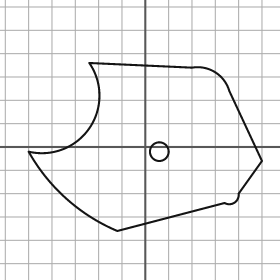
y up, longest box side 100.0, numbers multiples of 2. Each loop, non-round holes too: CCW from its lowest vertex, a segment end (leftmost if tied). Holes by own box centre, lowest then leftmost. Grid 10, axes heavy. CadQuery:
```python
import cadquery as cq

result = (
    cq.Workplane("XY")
    .moveTo(-12.0, -36.0)
    .lineTo(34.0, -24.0)
    .threePointArc((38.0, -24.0), (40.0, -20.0))
    .lineTo(50.0, -6.0)
    .lineTo(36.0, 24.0)
    .threePointArc((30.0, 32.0), (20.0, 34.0))
    .lineTo(-24.0, 36.0)
    .threePointArc((-24.0, 8.0), (-50.0, -2.0))
    .threePointArc((-34.0, -22.0), (-12.0, -36.0))
    .close()
    .moveTo(6.0, -2.0)
    .circle(4.0)
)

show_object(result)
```